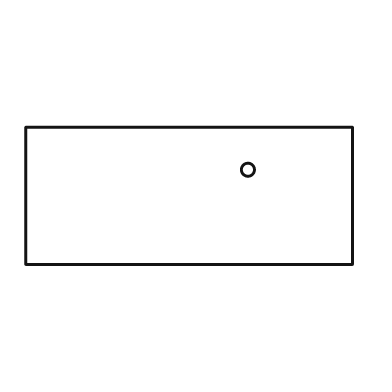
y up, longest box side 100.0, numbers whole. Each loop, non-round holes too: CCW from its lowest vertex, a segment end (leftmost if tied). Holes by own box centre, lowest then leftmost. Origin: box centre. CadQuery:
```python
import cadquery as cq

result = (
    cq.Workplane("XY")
    .moveTo(-50.0, -21.0)
    .lineTo(50.0, -21.0)
    .lineTo(50.0, 21.0)
    .lineTo(-50.0, 21.0)
    .close()
    .moveTo(18.0, 8.0)
    .circle(2.0)
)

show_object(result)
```